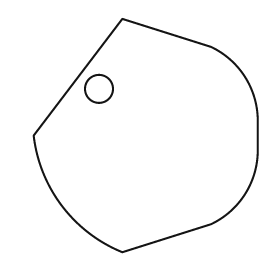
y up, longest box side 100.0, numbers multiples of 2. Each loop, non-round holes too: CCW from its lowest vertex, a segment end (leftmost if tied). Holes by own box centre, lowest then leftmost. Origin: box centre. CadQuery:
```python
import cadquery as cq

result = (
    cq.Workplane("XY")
    .moveTo(-10.0, -50.0)
    .lineTo(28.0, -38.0)
    .threePointArc((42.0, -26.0), (48.0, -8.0))
    .lineTo(48.0, 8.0)
    .threePointArc((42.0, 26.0), (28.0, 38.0))
    .lineTo(-10.0, 50.0)
    .lineTo(-48.0, 0.0)
    .threePointArc((-36.0, -30.0), (-10.0, -50.0))
    .close()
    .moveTo(-20.0, 20.0)
    .circle(6.0)
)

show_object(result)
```